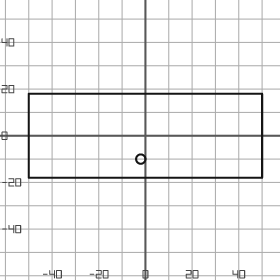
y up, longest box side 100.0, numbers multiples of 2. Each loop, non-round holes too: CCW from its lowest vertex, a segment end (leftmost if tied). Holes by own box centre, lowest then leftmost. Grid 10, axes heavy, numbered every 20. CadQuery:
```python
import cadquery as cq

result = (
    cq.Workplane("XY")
    .moveTo(-50.0, -18.0)
    .lineTo(50.0, -18.0)
    .lineTo(50.0, 18.0)
    .lineTo(-50.0, 18.0)
    .close()
    .moveTo(-2.0, -10.0)
    .circle(2.0)
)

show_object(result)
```